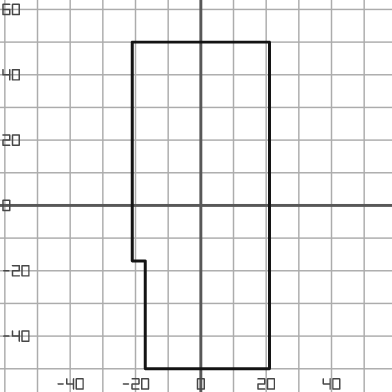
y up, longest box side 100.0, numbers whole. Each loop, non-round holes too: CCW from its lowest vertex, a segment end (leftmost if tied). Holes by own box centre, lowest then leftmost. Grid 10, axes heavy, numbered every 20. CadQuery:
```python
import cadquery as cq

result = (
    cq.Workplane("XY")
    .moveTo(-17.0, -50.0)
    .lineTo(21.0, -50.0)
    .lineTo(21.0, 50.0)
    .lineTo(-21.0, 50.0)
    .lineTo(-21.0, -17.0)
    .lineTo(-17.0, -17.0)
    .close()
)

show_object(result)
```